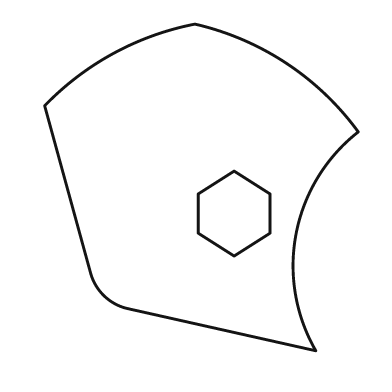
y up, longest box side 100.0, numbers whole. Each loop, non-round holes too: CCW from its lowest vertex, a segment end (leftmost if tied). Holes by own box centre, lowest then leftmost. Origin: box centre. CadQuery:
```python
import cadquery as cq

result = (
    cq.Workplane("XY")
    .moveTo(35.0, -50.0)
    .threePointArc((29.0, -14.0), (48.0, 17.0))
    .threePointArc((26.0, 38.0), (-2.0, 50.0))
    .threePointArc((-27.0, 41.0), (-48.0, 25.0))
    .lineTo(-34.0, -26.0)
    .threePointArc((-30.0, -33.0), (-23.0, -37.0))
    .close()
    .moveTo(10.0, -21.0)
    .lineTo(21.0, -14.0)
    .lineTo(21.0, -2.0)
    .lineTo(10.0, 5.0)
    .lineTo(-1.0, -2.0)
    .lineTo(-1.0, -14.0)
    .close()
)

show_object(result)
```